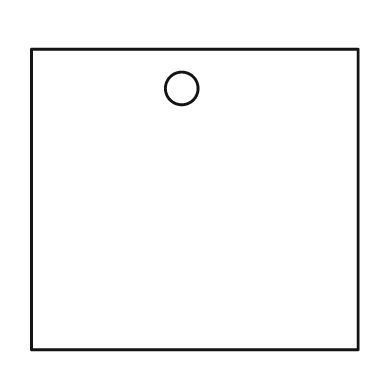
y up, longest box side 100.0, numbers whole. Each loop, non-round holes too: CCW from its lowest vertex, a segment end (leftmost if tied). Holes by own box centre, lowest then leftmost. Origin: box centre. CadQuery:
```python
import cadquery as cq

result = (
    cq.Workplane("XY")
    .moveTo(-50.0, -46.0)
    .lineTo(50.0, -46.0)
    .lineTo(50.0, 46.0)
    .lineTo(-50.0, 46.0)
    .close()
    .moveTo(-4.0, 34.0)
    .circle(5.0)
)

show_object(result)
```